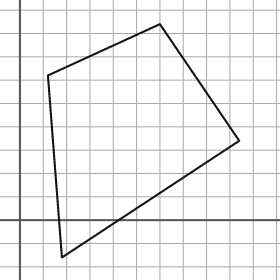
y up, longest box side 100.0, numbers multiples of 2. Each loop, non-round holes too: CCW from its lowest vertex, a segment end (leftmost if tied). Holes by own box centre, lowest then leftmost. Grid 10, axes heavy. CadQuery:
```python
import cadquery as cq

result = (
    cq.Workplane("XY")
    .moveTo(18.0, -16.0)
    .lineTo(94.0, 34.0)
    .lineTo(60.0, 84.0)
    .lineTo(12.0, 62.0)
    .close()
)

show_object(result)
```